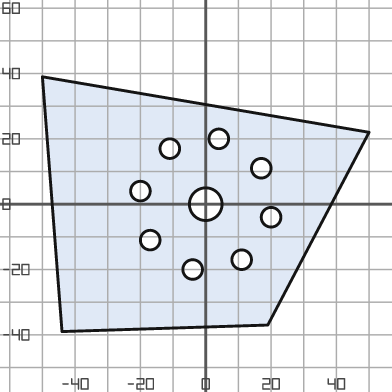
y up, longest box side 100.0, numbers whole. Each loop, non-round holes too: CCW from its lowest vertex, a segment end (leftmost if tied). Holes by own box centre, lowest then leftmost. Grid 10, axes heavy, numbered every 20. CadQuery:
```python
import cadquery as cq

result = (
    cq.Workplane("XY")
    .moveTo(-44.0, -39.0)
    .lineTo(19.0, -37.0)
    .lineTo(50.0, 22.0)
    .lineTo(-50.0, 39.0)
    .close()
    .moveTo(-4.0, -20.0)
    .circle(3.0)
    .moveTo(11.0, -17.0)
    .circle(3.0)
    .moveTo(-17.0, -11.0)
    .circle(3.0)
    .moveTo(20.0, -4.0)
    .circle(3.0)
    .moveTo(0.0, 0.0)
    .circle(5.0)
    .moveTo(-20.0, 4.0)
    .circle(3.0)
    .moveTo(17.0, 11.0)
    .circle(3.0)
    .moveTo(-11.0, 17.0)
    .circle(3.0)
    .moveTo(4.0, 20.0)
    .circle(3.0)
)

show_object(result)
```